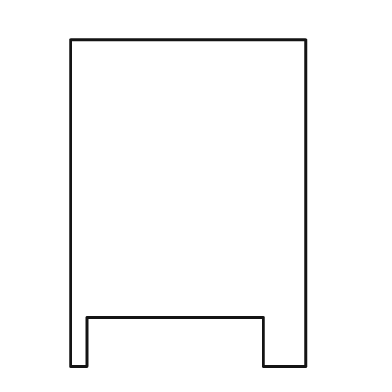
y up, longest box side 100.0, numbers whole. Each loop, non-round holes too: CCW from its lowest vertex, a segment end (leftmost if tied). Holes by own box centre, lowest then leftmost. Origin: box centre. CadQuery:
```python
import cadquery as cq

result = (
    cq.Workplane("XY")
    .moveTo(-36.0, -50.0)
    .lineTo(-31.0, -50.0)
    .lineTo(-31.0, -35.0)
    .lineTo(23.0, -35.0)
    .lineTo(23.0, -50.0)
    .lineTo(36.0, -50.0)
    .lineTo(36.0, 50.0)
    .lineTo(-36.0, 50.0)
    .close()
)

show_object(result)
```